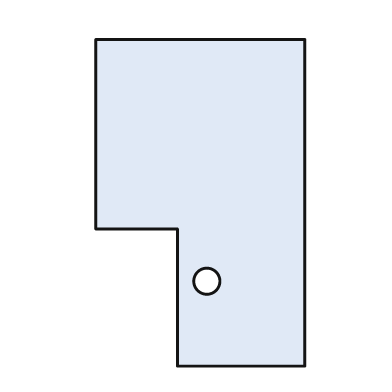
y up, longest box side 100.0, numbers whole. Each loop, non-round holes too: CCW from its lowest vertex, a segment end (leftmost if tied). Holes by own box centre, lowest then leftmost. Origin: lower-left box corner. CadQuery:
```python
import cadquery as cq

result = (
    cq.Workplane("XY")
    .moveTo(25.0, 0.0)
    .lineTo(64.0, 0.0)
    .lineTo(64.0, 100.0)
    .lineTo(0.0, 100.0)
    .lineTo(0.0, 42.0)
    .lineTo(25.0, 42.0)
    .close()
    .moveTo(34.0, 26.0)
    .circle(4.0)
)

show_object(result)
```